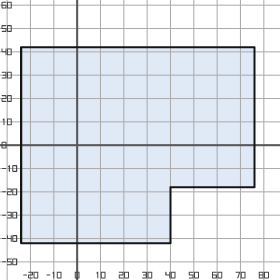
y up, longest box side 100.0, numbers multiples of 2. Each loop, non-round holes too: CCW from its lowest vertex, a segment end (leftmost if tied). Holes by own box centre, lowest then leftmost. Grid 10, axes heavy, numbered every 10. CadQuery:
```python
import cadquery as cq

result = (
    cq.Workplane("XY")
    .moveTo(-24.0, -42.0)
    .lineTo(40.0, -42.0)
    .lineTo(40.0, -18.0)
    .lineTo(76.0, -18.0)
    .lineTo(76.0, 42.0)
    .lineTo(-24.0, 42.0)
    .close()
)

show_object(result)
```